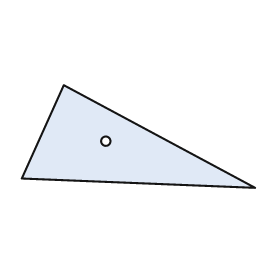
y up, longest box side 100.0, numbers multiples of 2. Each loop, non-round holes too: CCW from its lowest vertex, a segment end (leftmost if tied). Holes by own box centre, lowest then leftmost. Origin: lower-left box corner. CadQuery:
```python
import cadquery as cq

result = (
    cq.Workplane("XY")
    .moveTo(100.0, 0.0)
    .lineTo(18.0, 44.0)
    .lineTo(0.0, 4.0)
    .close()
    .moveTo(36.0, 20.0)
    .circle(2.0)
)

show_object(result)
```